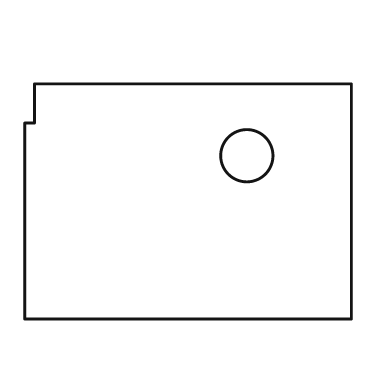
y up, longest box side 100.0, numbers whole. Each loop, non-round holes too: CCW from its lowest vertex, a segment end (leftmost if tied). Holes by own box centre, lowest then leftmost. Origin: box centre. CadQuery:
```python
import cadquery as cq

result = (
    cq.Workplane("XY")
    .moveTo(-50.0, -36.0)
    .lineTo(50.0, -36.0)
    .lineTo(50.0, 36.0)
    .lineTo(-47.0, 36.0)
    .lineTo(-47.0, 24.0)
    .lineTo(-50.0, 24.0)
    .close()
    .moveTo(18.0, 14.0)
    .circle(8.0)
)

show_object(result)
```